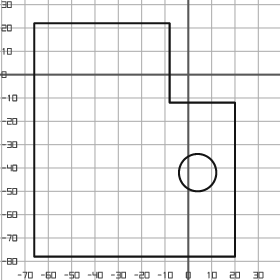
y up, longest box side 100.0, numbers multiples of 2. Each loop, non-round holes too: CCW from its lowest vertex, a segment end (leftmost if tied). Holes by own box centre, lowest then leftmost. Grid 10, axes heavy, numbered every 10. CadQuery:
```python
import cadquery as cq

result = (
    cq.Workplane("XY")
    .moveTo(-66.0, -78.0)
    .lineTo(20.0, -78.0)
    .lineTo(20.0, -12.0)
    .lineTo(-8.0, -12.0)
    .lineTo(-8.0, 22.0)
    .lineTo(-66.0, 22.0)
    .close()
    .moveTo(4.0, -42.0)
    .circle(8.0)
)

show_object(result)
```